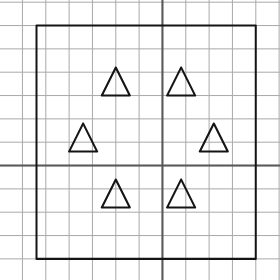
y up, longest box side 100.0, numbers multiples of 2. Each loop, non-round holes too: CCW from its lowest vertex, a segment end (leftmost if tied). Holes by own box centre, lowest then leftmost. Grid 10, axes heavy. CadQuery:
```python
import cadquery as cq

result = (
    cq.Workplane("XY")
    .moveTo(-54.0, -40.0)
    .lineTo(40.0, -40.0)
    .lineTo(40.0, 60.0)
    .lineTo(-54.0, 60.0)
    .close()
    .moveTo(-26.0, -18.0)
    .lineTo(-14.0, -18.0)
    .lineTo(-20.0, -6.0)
    .close()
    .moveTo(2.0, -18.0)
    .lineTo(14.0, -18.0)
    .lineTo(8.0, -6.0)
    .close()
    .moveTo(-40.0, 6.0)
    .lineTo(-28.0, 6.0)
    .lineTo(-34.0, 18.0)
    .close()
    .moveTo(16.0, 6.0)
    .lineTo(28.0, 6.0)
    .lineTo(22.0, 18.0)
    .close()
    .moveTo(-26.0, 30.0)
    .lineTo(-14.0, 30.0)
    .lineTo(-20.0, 42.0)
    .close()
    .moveTo(2.0, 30.0)
    .lineTo(14.0, 30.0)
    .lineTo(8.0, 42.0)
    .close()
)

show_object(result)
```